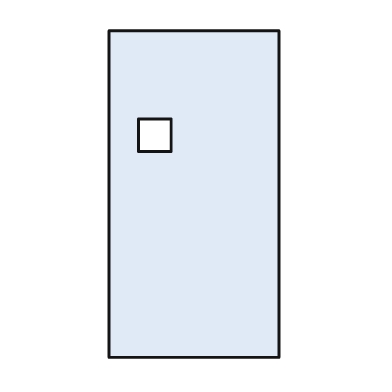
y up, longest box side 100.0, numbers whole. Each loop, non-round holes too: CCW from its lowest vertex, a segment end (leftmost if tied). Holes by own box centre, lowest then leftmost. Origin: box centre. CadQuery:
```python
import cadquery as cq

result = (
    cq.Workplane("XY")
    .moveTo(-26.0, -50.0)
    .lineTo(26.0, -50.0)
    .lineTo(26.0, 50.0)
    .lineTo(-26.0, 50.0)
    .close()
    .moveTo(-17.0, 13.0)
    .lineTo(-7.0, 13.0)
    .lineTo(-7.0, 23.0)
    .lineTo(-17.0, 23.0)
    .close()
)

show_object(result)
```